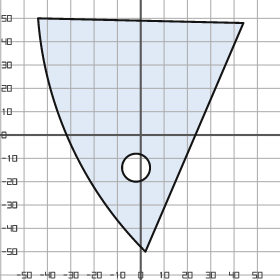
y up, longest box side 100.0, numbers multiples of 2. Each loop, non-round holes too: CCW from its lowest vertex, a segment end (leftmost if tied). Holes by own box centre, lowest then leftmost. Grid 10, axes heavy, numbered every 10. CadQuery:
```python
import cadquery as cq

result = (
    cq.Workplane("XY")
    .moveTo(2.0, -50.0)
    .lineTo(44.0, 48.0)
    .lineTo(-44.0, 50.0)
    .threePointArc((-30.0, -4.0), (2.0, -50.0))
    .close()
    .moveTo(-2.0, -14.0)
    .circle(6.0)
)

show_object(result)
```